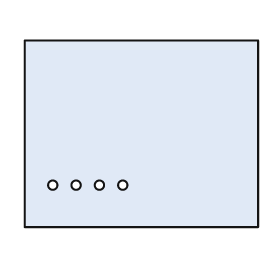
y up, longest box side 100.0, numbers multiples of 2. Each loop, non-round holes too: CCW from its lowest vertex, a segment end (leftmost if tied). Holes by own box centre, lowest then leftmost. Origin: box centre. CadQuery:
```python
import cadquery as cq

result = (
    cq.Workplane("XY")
    .moveTo(-50.0, -40.0)
    .lineTo(50.0, -40.0)
    .lineTo(50.0, 40.0)
    .lineTo(-50.0, 40.0)
    .close()
    .moveTo(-38.0, -22.0)
    .circle(2.0)
    .moveTo(-28.0, -22.0)
    .circle(2.0)
    .moveTo(-18.0, -22.0)
    .circle(2.0)
    .moveTo(-8.0, -22.0)
    .circle(2.0)
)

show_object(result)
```